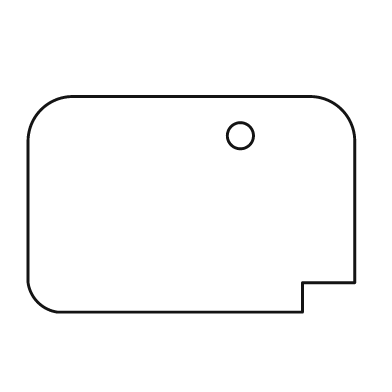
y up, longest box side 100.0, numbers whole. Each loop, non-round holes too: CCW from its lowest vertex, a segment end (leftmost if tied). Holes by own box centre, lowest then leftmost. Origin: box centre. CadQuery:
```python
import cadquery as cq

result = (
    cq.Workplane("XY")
    .moveTo(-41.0, -33.0)
    .lineTo(34.0, -33.0)
    .lineTo(34.0, -24.0)
    .lineTo(50.0, -24.0)
    .lineTo(50.0, 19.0)
    .threePointArc((46.0, 29.0), (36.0, 33.0))
    .lineTo(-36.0, 33.0)
    .threePointArc((-46.0, 29.0), (-50.0, 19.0))
    .lineTo(-50.0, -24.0)
    .threePointArc((-47.0, -30.0), (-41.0, -33.0))
    .close()
    .moveTo(15.0, 21.0)
    .circle(4.0)
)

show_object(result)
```